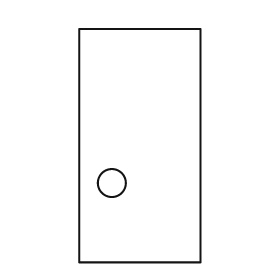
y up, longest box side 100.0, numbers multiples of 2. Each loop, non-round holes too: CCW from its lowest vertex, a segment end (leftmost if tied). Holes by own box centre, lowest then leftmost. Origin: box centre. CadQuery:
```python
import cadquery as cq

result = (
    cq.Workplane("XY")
    .moveTo(-26.0, -50.0)
    .lineTo(26.0, -50.0)
    .lineTo(26.0, 50.0)
    .lineTo(-26.0, 50.0)
    .close()
    .moveTo(-12.0, -16.0)
    .circle(6.0)
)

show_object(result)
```